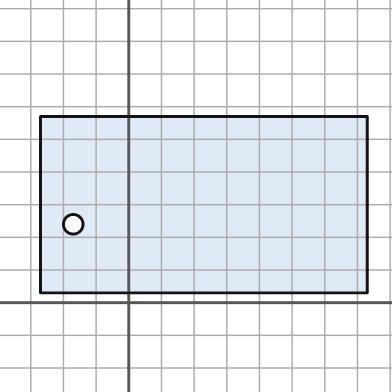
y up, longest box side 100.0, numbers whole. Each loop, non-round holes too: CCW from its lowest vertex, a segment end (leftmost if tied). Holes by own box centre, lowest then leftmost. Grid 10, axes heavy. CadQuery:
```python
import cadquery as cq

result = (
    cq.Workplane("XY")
    .moveTo(-27.0, 3.0)
    .lineTo(73.0, 3.0)
    .lineTo(73.0, 57.0)
    .lineTo(-27.0, 57.0)
    .close()
    .moveTo(-17.0, 24.0)
    .circle(3.0)
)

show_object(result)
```